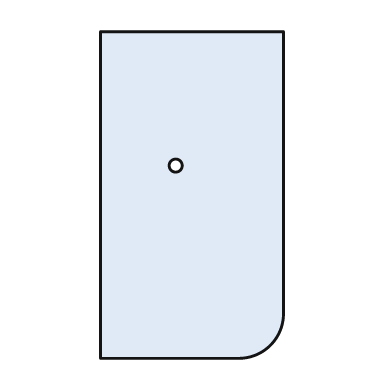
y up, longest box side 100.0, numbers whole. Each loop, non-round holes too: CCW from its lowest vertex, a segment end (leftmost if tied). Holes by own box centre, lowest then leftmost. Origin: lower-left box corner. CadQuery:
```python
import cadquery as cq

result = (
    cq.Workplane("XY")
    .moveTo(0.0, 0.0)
    .lineTo(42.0, 0.0)
    .threePointArc((52.0, 4.0), (56.0, 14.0))
    .lineTo(56.0, 100.0)
    .lineTo(0.0, 100.0)
    .close()
    .moveTo(23.0, 59.0)
    .circle(2.0)
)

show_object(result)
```